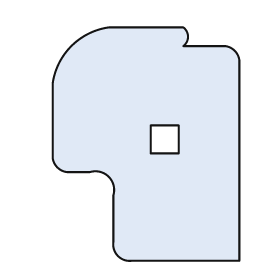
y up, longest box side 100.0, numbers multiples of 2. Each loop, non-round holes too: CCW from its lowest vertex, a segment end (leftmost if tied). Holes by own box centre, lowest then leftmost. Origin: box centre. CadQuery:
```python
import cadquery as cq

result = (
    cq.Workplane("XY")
    .moveTo(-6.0, -50.0)
    .lineTo(40.0, -50.0)
    .lineTo(40.0, 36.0)
    .threePointArc((38.0, 40.0), (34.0, 42.0))
    .lineTo(16.0, 42.0)
    .threePointArc((18.0, 46.0), (16.0, 50.0))
    .lineTo(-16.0, 50.0)
    .threePointArc((-32.0, 42.0), (-40.0, 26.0))
    .lineTo(-40.0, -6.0)
    .threePointArc((-38.0, -10.0), (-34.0, -12.0))
    .lineTo(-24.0, -12.0)
    .threePointArc((-16.0, -14.0), (-14.0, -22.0))
    .lineTo(-14.0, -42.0)
    .threePointArc((-12.0, -48.0), (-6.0, -50.0))
    .close()
    .moveTo(2.0, -4.0)
    .lineTo(14.0, -4.0)
    .lineTo(14.0, 8.0)
    .lineTo(2.0, 8.0)
    .close()
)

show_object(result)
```